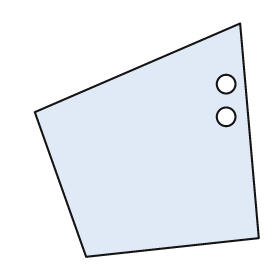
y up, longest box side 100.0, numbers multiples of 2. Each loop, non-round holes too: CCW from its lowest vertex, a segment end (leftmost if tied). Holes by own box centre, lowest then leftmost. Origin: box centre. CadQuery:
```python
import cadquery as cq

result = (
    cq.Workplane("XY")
    .moveTo(-26.0, -50.0)
    .lineTo(48.0, -42.0)
    .lineTo(40.0, 50.0)
    .lineTo(-48.0, 12.0)
    .close()
    .moveTo(34.0, 10.0)
    .circle(4.0)
    .moveTo(34.0, 24.0)
    .circle(4.0)
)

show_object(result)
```